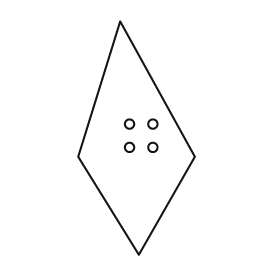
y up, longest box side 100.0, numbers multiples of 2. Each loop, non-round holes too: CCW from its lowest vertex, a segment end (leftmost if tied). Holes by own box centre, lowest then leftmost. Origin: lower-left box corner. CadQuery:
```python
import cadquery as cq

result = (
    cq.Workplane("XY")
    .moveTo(26.0, 0.0)
    .lineTo(50.0, 42.0)
    .lineTo(18.0, 100.0)
    .lineTo(0.0, 42.0)
    .close()
    .moveTo(22.0, 46.0)
    .circle(2.0)
    .moveTo(32.0, 46.0)
    .circle(2.0)
    .moveTo(22.0, 56.0)
    .circle(2.0)
    .moveTo(32.0, 56.0)
    .circle(2.0)
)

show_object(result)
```